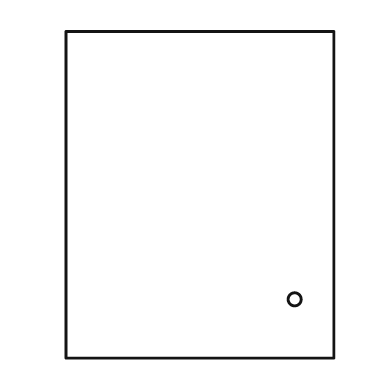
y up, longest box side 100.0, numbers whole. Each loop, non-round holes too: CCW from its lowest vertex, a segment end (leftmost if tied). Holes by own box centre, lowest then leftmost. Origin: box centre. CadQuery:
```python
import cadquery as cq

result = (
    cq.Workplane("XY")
    .moveTo(-41.0, -50.0)
    .lineTo(41.0, -50.0)
    .lineTo(41.0, 50.0)
    .lineTo(-41.0, 50.0)
    .close()
    .moveTo(29.0, -32.0)
    .circle(2.0)
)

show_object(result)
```